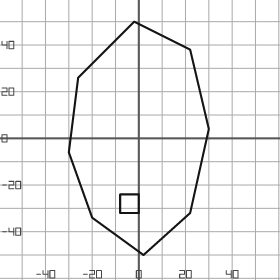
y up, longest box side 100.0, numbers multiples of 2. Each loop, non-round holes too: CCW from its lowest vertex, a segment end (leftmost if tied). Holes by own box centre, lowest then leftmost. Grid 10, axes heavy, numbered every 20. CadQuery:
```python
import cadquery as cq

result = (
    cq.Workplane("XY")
    .moveTo(2.0, -50.0)
    .lineTo(22.0, -32.0)
    .lineTo(30.0, 4.0)
    .lineTo(22.0, 38.0)
    .lineTo(-2.0, 50.0)
    .lineTo(-26.0, 26.0)
    .lineTo(-30.0, -6.0)
    .lineTo(-20.0, -34.0)
    .close()
    .moveTo(-8.0, -32.0)
    .lineTo(0.0, -32.0)
    .lineTo(0.0, -24.0)
    .lineTo(-8.0, -24.0)
    .close()
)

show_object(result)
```